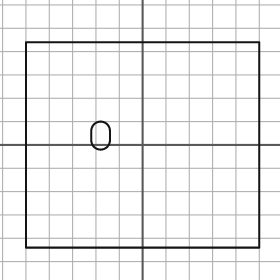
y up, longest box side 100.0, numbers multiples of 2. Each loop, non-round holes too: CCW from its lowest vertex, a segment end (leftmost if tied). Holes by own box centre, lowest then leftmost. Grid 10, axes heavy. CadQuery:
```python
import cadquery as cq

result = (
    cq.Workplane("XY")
    .moveTo(-50.0, -44.0)
    .lineTo(50.0, -44.0)
    .lineTo(50.0, 44.0)
    .lineTo(-50.0, 44.0)
    .close()
    .moveTo(-22.0, 2.0)
    .threePointArc((-18.0, -2.0), (-14.0, 2.0))
    .lineTo(-14.0, 6.0)
    .threePointArc((-18.0, 10.0), (-22.0, 6.0))
    .close()
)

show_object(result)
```